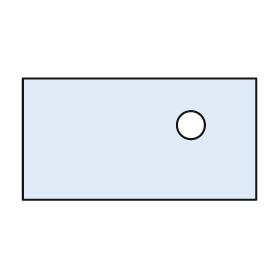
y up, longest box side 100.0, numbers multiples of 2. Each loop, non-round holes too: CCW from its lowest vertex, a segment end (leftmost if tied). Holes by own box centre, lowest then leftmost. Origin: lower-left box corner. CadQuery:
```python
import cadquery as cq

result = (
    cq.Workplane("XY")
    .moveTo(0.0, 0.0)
    .lineTo(100.0, 0.0)
    .lineTo(100.0, 52.0)
    .lineTo(0.0, 52.0)
    .close()
    .moveTo(72.0, 32.0)
    .circle(6.0)
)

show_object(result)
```